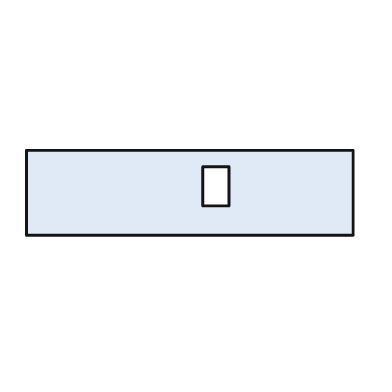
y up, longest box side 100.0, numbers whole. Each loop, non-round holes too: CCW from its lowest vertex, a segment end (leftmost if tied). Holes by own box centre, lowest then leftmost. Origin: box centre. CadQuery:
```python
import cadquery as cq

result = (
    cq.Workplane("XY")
    .moveTo(-50.0, -13.0)
    .lineTo(50.0, -13.0)
    .lineTo(50.0, 13.0)
    .lineTo(-50.0, 13.0)
    .close()
    .moveTo(4.0, -4.0)
    .lineTo(12.0, -4.0)
    .lineTo(12.0, 8.0)
    .lineTo(4.0, 8.0)
    .close()
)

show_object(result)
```